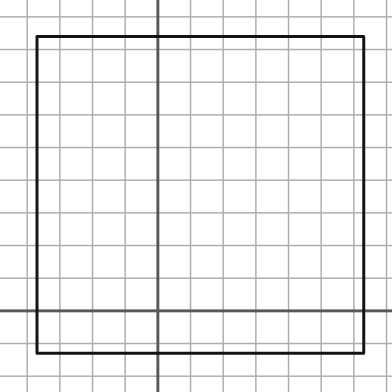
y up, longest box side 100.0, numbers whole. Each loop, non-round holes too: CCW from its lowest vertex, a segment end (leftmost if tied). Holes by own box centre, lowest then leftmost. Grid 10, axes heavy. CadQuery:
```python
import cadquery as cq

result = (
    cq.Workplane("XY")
    .moveTo(-37.0, -13.0)
    .lineTo(63.0, -13.0)
    .lineTo(63.0, 84.0)
    .lineTo(-37.0, 84.0)
    .close()
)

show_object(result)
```